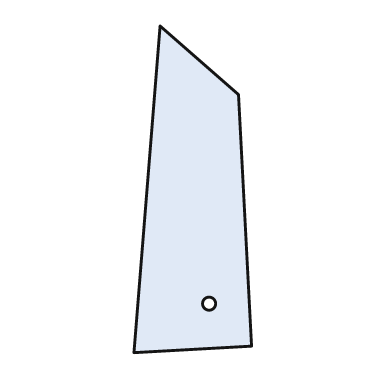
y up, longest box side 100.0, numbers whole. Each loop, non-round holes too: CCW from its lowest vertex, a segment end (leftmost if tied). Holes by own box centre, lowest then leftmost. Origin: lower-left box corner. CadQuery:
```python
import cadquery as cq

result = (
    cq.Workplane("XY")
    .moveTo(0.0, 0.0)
    .lineTo(36.0, 2.0)
    .lineTo(32.0, 79.0)
    .lineTo(8.0, 100.0)
    .close()
    .moveTo(23.0, 15.0)
    .circle(2.0)
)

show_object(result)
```